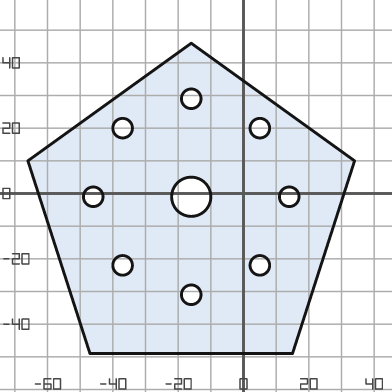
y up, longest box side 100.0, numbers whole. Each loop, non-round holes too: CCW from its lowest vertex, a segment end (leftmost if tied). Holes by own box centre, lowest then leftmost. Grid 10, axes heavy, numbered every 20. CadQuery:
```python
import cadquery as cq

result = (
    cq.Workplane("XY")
    .moveTo(-47.0, -49.0)
    .lineTo(15.0, -49.0)
    .lineTo(34.0, 10.0)
    .lineTo(-16.0, 46.0)
    .lineTo(-66.0, 10.0)
    .close()
    .moveTo(-16.0, -31.0)
    .circle(3.0)
    .moveTo(-37.0, -22.0)
    .circle(3.0)
    .moveTo(5.0, -22.0)
    .circle(3.0)
    .moveTo(-46.0, -1.0)
    .circle(3.0)
    .moveTo(-16.0, -1.0)
    .circle(6.0)
    .moveTo(14.0, -1.0)
    .circle(3.0)
    .moveTo(-37.0, 20.0)
    .circle(3.0)
    .moveTo(5.0, 20.0)
    .circle(3.0)
    .moveTo(-16.0, 29.0)
    .circle(3.0)
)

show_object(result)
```